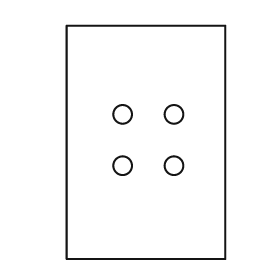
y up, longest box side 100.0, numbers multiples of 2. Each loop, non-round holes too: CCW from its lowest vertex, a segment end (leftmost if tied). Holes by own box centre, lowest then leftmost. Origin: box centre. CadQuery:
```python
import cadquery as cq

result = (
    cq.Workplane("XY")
    .moveTo(-34.0, -50.0)
    .lineTo(34.0, -50.0)
    .lineTo(34.0, 50.0)
    .lineTo(-34.0, 50.0)
    .close()
    .moveTo(-10.0, -10.0)
    .circle(4.0)
    .moveTo(12.0, -10.0)
    .circle(4.0)
    .moveTo(-10.0, 12.0)
    .circle(4.0)
    .moveTo(12.0, 12.0)
    .circle(4.0)
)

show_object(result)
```